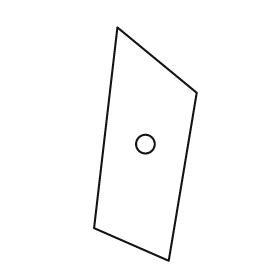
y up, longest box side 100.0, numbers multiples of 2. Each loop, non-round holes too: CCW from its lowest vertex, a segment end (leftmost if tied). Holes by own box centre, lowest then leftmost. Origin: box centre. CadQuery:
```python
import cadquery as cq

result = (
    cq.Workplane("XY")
    .moveTo(10.0, -50.0)
    .lineTo(22.0, 22.0)
    .lineTo(-12.0, 50.0)
    .lineTo(-22.0, -36.0)
    .close()
    .moveTo(0.0, 0.0)
    .circle(4.0)
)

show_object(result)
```